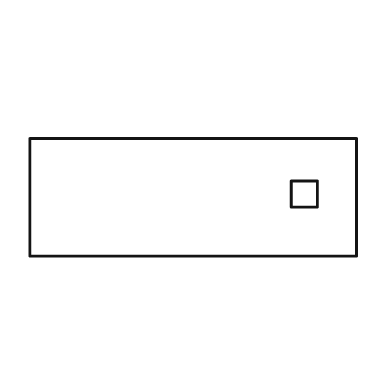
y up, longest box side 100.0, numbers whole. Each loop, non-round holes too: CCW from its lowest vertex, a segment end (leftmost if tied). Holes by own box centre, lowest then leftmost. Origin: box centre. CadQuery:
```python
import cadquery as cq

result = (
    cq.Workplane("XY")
    .moveTo(-50.0, -18.0)
    .lineTo(50.0, -18.0)
    .lineTo(50.0, 18.0)
    .lineTo(-50.0, 18.0)
    .close()
    .moveTo(30.0, -3.0)
    .lineTo(38.0, -3.0)
    .lineTo(38.0, 5.0)
    .lineTo(30.0, 5.0)
    .close()
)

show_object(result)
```